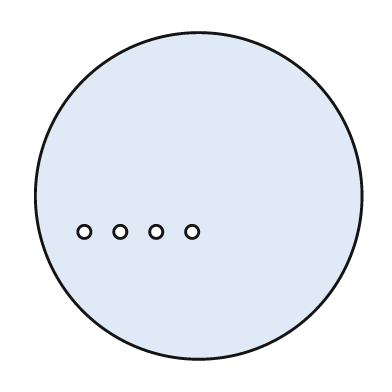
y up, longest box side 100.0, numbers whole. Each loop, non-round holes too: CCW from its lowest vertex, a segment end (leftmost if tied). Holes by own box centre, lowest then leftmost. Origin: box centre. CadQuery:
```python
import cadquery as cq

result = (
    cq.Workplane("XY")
    .moveTo(0.0, 0.0)
    .circle(50.0)
    .moveTo(-35.0, -11.0)
    .circle(2.0)
    .moveTo(-24.0, -11.0)
    .circle(2.0)
    .moveTo(-13.0, -11.0)
    .circle(2.0)
    .moveTo(-2.0, -11.0)
    .circle(2.0)
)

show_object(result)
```